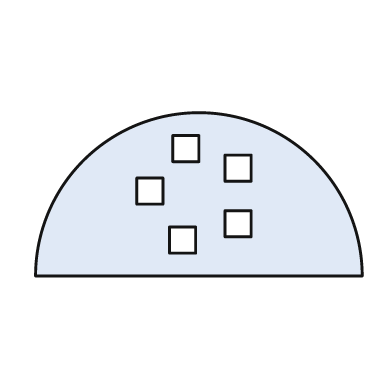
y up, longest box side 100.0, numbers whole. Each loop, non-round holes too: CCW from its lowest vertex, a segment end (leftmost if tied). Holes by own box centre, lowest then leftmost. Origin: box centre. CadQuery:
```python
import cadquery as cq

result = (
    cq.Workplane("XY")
    .moveTo(-50.0, -25.0)
    .lineTo(50.0, -25.0)
    .threePointArc((0.0, 25.0), (-50.0, -25.0))
    .close()
    .moveTo(-9.0, -18.0)
    .lineTo(-1.0, -18.0)
    .lineTo(-1.0, -10.0)
    .lineTo(-9.0, -10.0)
    .close()
    .moveTo(8.0, -13.0)
    .lineTo(16.0, -13.0)
    .lineTo(16.0, -5.0)
    .lineTo(8.0, -5.0)
    .close()
    .moveTo(-19.0, -3.0)
    .lineTo(-11.0, -3.0)
    .lineTo(-11.0, 5.0)
    .lineTo(-19.0, 5.0)
    .close()
    .moveTo(8.0, 4.0)
    .lineTo(16.0, 4.0)
    .lineTo(16.0, 12.0)
    .lineTo(8.0, 12.0)
    .close()
    .moveTo(-8.0, 10.0)
    .lineTo(0.0, 10.0)
    .lineTo(0.0, 18.0)
    .lineTo(-8.0, 18.0)
    .close()
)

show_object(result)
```